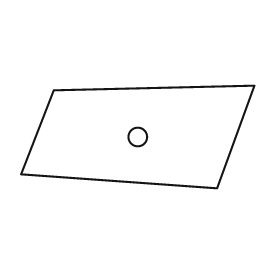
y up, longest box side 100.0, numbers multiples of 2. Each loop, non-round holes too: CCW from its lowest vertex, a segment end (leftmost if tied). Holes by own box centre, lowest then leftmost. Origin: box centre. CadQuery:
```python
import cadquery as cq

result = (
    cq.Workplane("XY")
    .moveTo(34.0, -22.0)
    .lineTo(50.0, 22.0)
    .lineTo(-36.0, 20.0)
    .lineTo(-50.0, -16.0)
    .close()
    .moveTo(0.0, 0.0)
    .circle(4.0)
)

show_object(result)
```